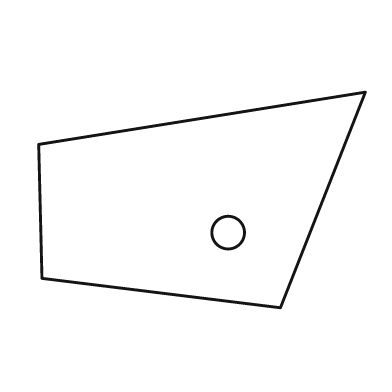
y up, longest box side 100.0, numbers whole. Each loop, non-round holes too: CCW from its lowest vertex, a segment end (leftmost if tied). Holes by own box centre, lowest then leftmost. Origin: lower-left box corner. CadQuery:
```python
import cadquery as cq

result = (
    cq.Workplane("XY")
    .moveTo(74.0, 0.0)
    .lineTo(100.0, 66.0)
    .lineTo(0.0, 50.0)
    .lineTo(1.0, 9.0)
    .close()
    .moveTo(58.0, 23.0)
    .circle(5.0)
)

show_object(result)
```